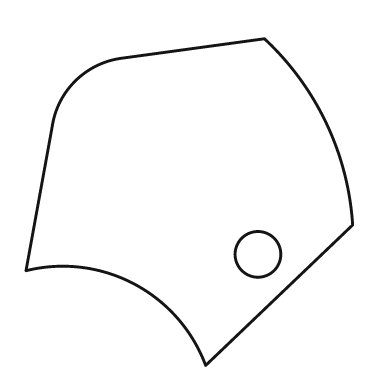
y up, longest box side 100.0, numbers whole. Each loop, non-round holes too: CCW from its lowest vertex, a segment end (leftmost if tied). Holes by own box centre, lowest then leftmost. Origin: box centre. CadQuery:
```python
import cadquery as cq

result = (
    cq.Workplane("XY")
    .moveTo(5.0, -50.0)
    .lineTo(50.0, -7.0)
    .threePointArc((42.0, 24.0), (23.0, 50.0))
    .lineTo(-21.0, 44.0)
    .threePointArc((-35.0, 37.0), (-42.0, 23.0))
    .lineTo(-50.0, -21.0)
    .threePointArc((-17.0, -25.0), (5.0, -50.0))
    .close()
    .moveTo(21.0, -16.0)
    .circle(7.0)
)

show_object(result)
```